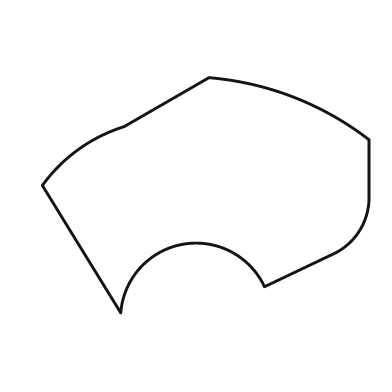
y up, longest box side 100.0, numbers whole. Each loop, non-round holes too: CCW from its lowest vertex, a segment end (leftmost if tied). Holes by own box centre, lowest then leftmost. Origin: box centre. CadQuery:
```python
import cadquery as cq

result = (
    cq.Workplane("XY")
    .moveTo(-26.0, -36.0)
    .threePointArc((-7.0, -15.0), (18.0, -28.0))
    .lineTo(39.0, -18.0)
    .threePointArc((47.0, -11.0), (50.0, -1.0))
    .lineTo(50.0, 17.0)
    .threePointArc((27.0, 30.0), (1.0, 36.0))
    .lineTo(-25.0, 21.0)
    .threePointArc((-39.0, 14.0), (-50.0, 3.0))
    .close()
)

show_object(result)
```